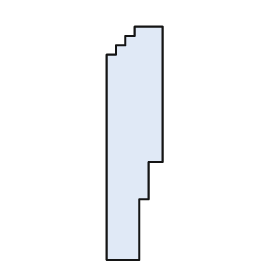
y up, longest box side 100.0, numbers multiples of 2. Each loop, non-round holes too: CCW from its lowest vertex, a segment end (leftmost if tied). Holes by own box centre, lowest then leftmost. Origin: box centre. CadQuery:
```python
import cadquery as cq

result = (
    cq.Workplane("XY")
    .moveTo(-12.0, -50.0)
    .lineTo(2.0, -50.0)
    .lineTo(2.0, -24.0)
    .lineTo(6.0, -24.0)
    .lineTo(6.0, -8.0)
    .lineTo(12.0, -8.0)
    .lineTo(12.0, 50.0)
    .lineTo(0.0, 50.0)
    .lineTo(0.0, 46.0)
    .lineTo(-4.0, 46.0)
    .lineTo(-4.0, 42.0)
    .lineTo(-8.0, 42.0)
    .lineTo(-8.0, 38.0)
    .lineTo(-12.0, 38.0)
    .close()
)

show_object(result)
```